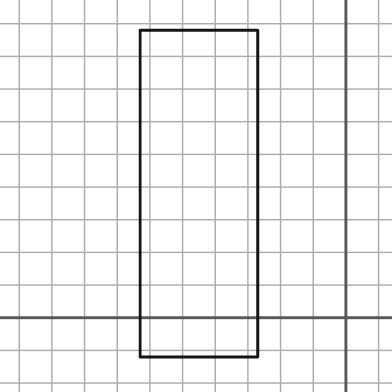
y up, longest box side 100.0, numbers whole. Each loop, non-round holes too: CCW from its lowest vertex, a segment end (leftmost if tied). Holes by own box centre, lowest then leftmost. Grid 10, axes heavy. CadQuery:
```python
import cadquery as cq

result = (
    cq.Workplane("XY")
    .moveTo(-63.0, -12.0)
    .lineTo(-27.0, -12.0)
    .lineTo(-27.0, 88.0)
    .lineTo(-63.0, 88.0)
    .close()
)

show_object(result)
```